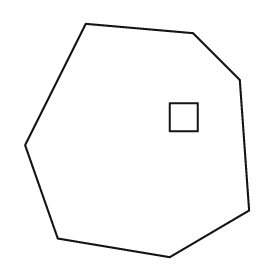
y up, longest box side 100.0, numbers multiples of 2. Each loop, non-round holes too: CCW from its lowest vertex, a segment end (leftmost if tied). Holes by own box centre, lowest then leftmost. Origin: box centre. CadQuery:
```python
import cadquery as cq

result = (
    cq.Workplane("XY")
    .moveTo(14.0, -50.0)
    .lineTo(48.0, -30.0)
    .lineTo(44.0, 26.0)
    .lineTo(24.0, 46.0)
    .lineTo(-22.0, 50.0)
    .lineTo(-48.0, -2.0)
    .lineTo(-34.0, -42.0)
    .close()
    .moveTo(14.0, 4.0)
    .lineTo(26.0, 4.0)
    .lineTo(26.0, 16.0)
    .lineTo(14.0, 16.0)
    .close()
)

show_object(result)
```